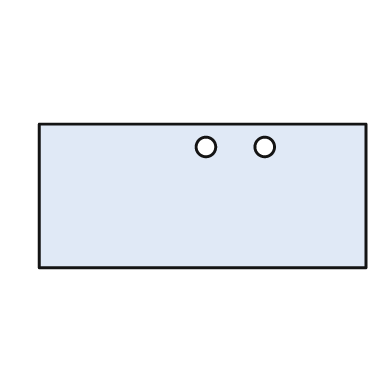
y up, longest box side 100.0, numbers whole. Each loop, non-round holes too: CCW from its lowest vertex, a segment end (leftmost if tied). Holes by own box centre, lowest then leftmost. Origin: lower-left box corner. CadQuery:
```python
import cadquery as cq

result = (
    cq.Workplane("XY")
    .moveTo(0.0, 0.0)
    .lineTo(100.0, 0.0)
    .lineTo(100.0, 44.0)
    .lineTo(0.0, 44.0)
    .close()
    .moveTo(51.0, 37.0)
    .circle(3.0)
    .moveTo(69.0, 37.0)
    .circle(3.0)
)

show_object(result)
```